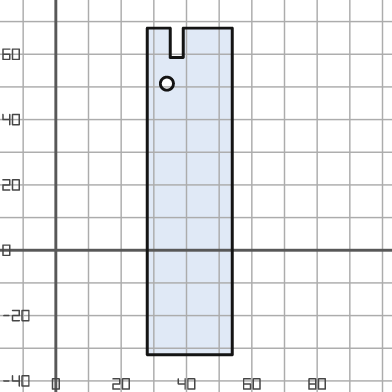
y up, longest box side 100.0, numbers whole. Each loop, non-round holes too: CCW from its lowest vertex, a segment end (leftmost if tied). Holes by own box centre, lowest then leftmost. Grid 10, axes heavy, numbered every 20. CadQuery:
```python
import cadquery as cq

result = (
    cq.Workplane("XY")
    .moveTo(28.0, -32.0)
    .lineTo(54.0, -32.0)
    .lineTo(54.0, 68.0)
    .lineTo(39.0, 68.0)
    .lineTo(39.0, 59.0)
    .lineTo(35.0, 59.0)
    .lineTo(35.0, 68.0)
    .lineTo(28.0, 68.0)
    .close()
    .moveTo(34.0, 51.0)
    .circle(2.0)
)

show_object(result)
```